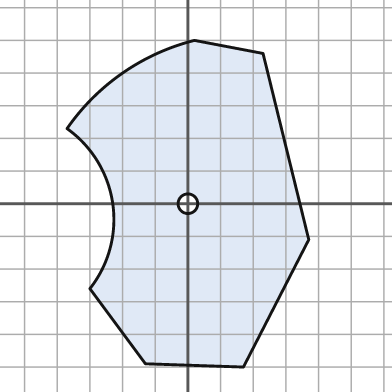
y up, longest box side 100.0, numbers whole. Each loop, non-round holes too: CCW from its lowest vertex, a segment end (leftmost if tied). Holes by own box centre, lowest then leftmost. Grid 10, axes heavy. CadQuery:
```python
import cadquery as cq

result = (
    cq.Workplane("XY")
    .moveTo(17.0, -50.0)
    .lineTo(37.0, -11.0)
    .lineTo(23.0, 46.0)
    .lineTo(2.0, 50.0)
    .threePointArc((-20.0, 40.0), (-37.0, 23.0))
    .threePointArc((-23.0, 0.0), (-30.0, -26.0))
    .lineTo(-13.0, -49.0)
    .close()
    .moveTo(0.0, 0.0)
    .circle(3.0)
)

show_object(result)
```